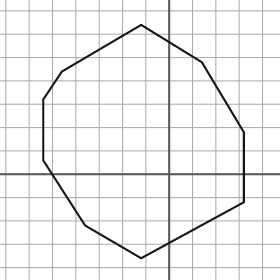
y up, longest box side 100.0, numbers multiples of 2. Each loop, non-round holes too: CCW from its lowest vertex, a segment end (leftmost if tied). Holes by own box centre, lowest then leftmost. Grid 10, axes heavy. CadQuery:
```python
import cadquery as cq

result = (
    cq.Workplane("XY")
    .moveTo(-12.0, -36.0)
    .lineTo(32.0, -12.0)
    .lineTo(32.0, 18.0)
    .lineTo(14.0, 48.0)
    .lineTo(-12.0, 64.0)
    .lineTo(-46.0, 44.0)
    .lineTo(-54.0, 32.0)
    .lineTo(-54.0, 6.0)
    .lineTo(-36.0, -22.0)
    .close()
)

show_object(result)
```